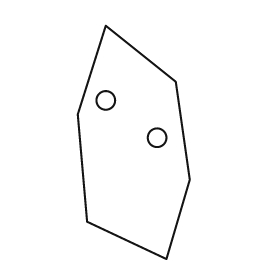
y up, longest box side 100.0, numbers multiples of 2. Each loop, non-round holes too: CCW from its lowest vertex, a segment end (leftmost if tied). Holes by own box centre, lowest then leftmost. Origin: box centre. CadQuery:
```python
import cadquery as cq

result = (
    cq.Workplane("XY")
    .moveTo(14.0, -50.0)
    .lineTo(24.0, -16.0)
    .lineTo(18.0, 26.0)
    .lineTo(-12.0, 50.0)
    .lineTo(-24.0, 12.0)
    .lineTo(-20.0, -34.0)
    .close()
    .moveTo(10.0, 2.0)
    .circle(4.0)
    .moveTo(-12.0, 18.0)
    .circle(4.0)
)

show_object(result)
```